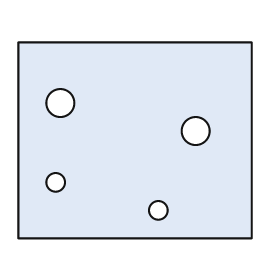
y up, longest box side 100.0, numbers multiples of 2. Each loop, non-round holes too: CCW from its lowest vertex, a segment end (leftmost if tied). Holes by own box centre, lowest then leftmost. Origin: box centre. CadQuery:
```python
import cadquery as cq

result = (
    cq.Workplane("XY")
    .moveTo(-50.0, -42.0)
    .lineTo(50.0, -42.0)
    .lineTo(50.0, 42.0)
    .lineTo(-50.0, 42.0)
    .close()
    .moveTo(10.0, -30.0)
    .circle(4.0)
    .moveTo(-34.0, -18.0)
    .circle(4.0)
    .moveTo(26.0, 4.0)
    .circle(6.0)
    .moveTo(-32.0, 16.0)
    .circle(6.0)
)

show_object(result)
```